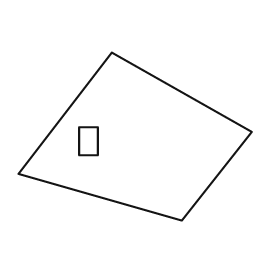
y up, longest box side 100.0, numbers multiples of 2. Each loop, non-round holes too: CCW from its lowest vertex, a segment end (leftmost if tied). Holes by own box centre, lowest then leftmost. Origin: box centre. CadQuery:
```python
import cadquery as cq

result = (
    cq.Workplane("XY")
    .moveTo(20.0, -36.0)
    .lineTo(50.0, 2.0)
    .lineTo(-10.0, 36.0)
    .lineTo(-50.0, -16.0)
    .close()
    .moveTo(-24.0, -8.0)
    .lineTo(-16.0, -8.0)
    .lineTo(-16.0, 4.0)
    .lineTo(-24.0, 4.0)
    .close()
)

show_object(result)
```